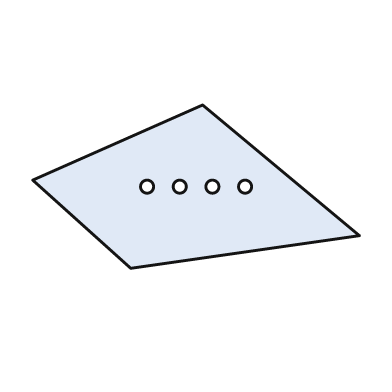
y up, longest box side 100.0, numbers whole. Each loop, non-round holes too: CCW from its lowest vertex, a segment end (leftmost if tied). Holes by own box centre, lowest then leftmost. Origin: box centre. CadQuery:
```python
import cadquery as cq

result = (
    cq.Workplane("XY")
    .moveTo(-20.0, -25.0)
    .lineTo(50.0, -15.0)
    .lineTo(2.0, 25.0)
    .lineTo(-50.0, 2.0)
    .close()
    .moveTo(-15.0, 0.0)
    .circle(2.0)
    .moveTo(-5.0, 0.0)
    .circle(2.0)
    .moveTo(5.0, 0.0)
    .circle(2.0)
    .moveTo(15.0, 0.0)
    .circle(2.0)
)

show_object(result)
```